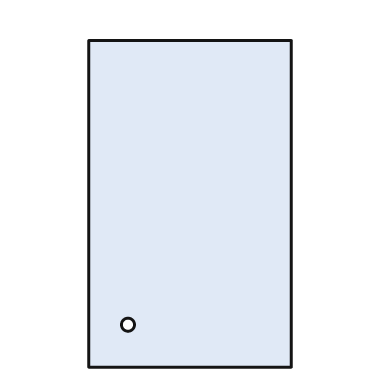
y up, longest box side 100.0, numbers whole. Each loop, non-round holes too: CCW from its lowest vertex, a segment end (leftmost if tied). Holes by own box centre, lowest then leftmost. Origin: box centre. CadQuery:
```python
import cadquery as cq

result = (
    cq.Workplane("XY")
    .moveTo(-31.0, -50.0)
    .lineTo(31.0, -50.0)
    .lineTo(31.0, 50.0)
    .lineTo(-31.0, 50.0)
    .close()
    .moveTo(-19.0, -37.0)
    .circle(2.0)
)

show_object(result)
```